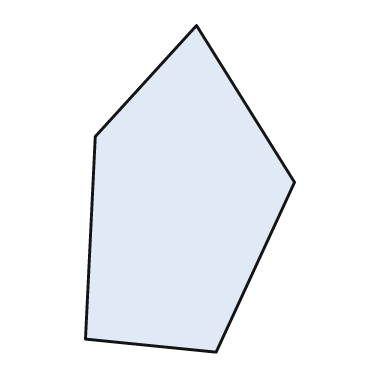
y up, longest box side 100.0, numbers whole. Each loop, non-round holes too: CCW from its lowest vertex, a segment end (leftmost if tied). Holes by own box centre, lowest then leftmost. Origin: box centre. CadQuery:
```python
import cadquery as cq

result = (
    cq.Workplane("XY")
    .moveTo(8.0, -50.0)
    .lineTo(32.0, 2.0)
    .lineTo(2.0, 50.0)
    .lineTo(-29.0, 16.0)
    .lineTo(-32.0, -46.0)
    .close()
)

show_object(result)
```